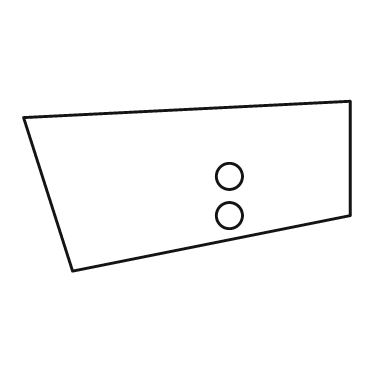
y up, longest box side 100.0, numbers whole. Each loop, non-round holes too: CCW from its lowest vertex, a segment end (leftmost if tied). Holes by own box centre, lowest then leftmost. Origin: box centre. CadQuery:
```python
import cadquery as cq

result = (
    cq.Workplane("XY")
    .moveTo(-35.0, -26.0)
    .lineTo(50.0, -9.0)
    .lineTo(50.0, 26.0)
    .lineTo(-50.0, 21.0)
    .close()
    .moveTo(13.0, -9.0)
    .circle(4.0)
    .moveTo(13.0, 3.0)
    .circle(4.0)
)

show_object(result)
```